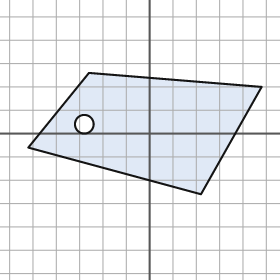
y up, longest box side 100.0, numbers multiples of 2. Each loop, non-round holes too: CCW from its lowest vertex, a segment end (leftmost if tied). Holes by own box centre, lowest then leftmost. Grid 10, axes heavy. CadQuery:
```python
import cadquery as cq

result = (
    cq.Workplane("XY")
    .moveTo(22.0, -26.0)
    .lineTo(48.0, 20.0)
    .lineTo(-26.0, 26.0)
    .lineTo(-52.0, -6.0)
    .close()
    .moveTo(-28.0, 4.0)
    .circle(4.0)
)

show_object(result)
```